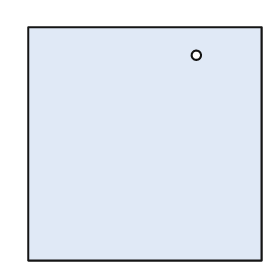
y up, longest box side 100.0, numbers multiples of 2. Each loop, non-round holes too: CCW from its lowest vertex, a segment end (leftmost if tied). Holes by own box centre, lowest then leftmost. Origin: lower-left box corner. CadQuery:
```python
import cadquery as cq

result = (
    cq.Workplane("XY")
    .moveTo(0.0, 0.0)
    .lineTo(100.0, 0.0)
    .lineTo(100.0, 100.0)
    .lineTo(0.0, 100.0)
    .close()
    .moveTo(72.0, 88.0)
    .circle(2.0)
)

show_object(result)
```